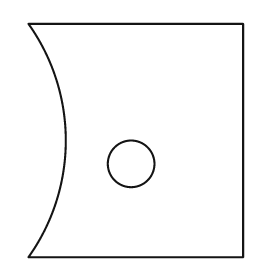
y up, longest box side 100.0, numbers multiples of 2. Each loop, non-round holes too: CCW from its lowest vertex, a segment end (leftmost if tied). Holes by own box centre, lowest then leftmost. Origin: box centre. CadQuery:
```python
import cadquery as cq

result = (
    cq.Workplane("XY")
    .moveTo(-46.0, -50.0)
    .lineTo(46.0, -50.0)
    .lineTo(46.0, 50.0)
    .lineTo(-46.0, 50.0)
    .threePointArc((-30.0, 0.0), (-46.0, -50.0))
    .close()
    .moveTo(-2.0, -10.0)
    .circle(10.0)
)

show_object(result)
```